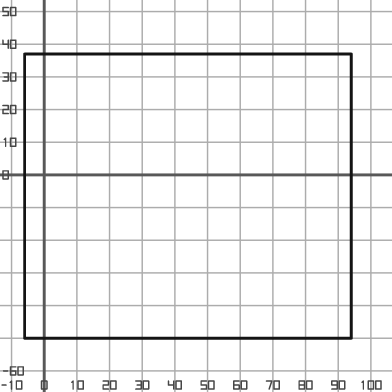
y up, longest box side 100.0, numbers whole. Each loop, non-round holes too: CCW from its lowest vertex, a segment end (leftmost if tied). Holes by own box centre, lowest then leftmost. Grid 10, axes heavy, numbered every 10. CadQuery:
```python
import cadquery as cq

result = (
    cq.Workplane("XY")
    .moveTo(-6.0, -50.0)
    .lineTo(94.0, -50.0)
    .lineTo(94.0, 37.0)
    .lineTo(-6.0, 37.0)
    .close()
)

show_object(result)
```